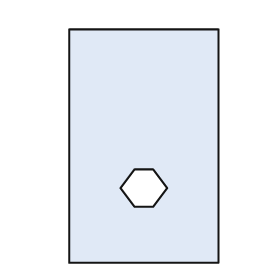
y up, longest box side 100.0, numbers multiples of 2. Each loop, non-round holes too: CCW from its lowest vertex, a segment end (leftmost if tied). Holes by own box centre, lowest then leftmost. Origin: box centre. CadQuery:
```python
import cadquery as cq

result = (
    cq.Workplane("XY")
    .moveTo(-32.0, -50.0)
    .lineTo(32.0, -50.0)
    .lineTo(32.0, 50.0)
    .lineTo(-32.0, 50.0)
    .close()
    .moveTo(-4.0, -26.0)
    .lineTo(4.0, -26.0)
    .lineTo(10.0, -18.0)
    .lineTo(4.0, -10.0)
    .lineTo(-4.0, -10.0)
    .lineTo(-10.0, -18.0)
    .close()
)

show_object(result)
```